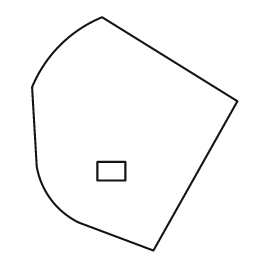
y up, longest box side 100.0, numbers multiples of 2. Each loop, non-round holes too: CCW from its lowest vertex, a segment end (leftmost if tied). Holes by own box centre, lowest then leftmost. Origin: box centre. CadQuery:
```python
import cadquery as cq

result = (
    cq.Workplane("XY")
    .moveTo(8.0, -50.0)
    .lineTo(44.0, 14.0)
    .lineTo(-14.0, 50.0)
    .threePointArc((-32.0, 38.0), (-44.0, 20.0))
    .lineTo(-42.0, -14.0)
    .threePointArc((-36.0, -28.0), (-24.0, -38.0))
    .close()
    .moveTo(-16.0, -20.0)
    .lineTo(-4.0, -20.0)
    .lineTo(-4.0, -12.0)
    .lineTo(-16.0, -12.0)
    .close()
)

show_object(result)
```